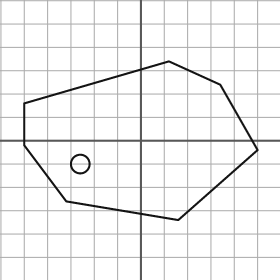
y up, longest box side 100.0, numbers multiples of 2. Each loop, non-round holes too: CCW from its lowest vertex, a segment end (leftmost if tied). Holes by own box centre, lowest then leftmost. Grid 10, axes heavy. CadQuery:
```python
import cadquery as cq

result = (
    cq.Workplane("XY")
    .moveTo(16.0, -34.0)
    .lineTo(50.0, -4.0)
    .lineTo(34.0, 24.0)
    .lineTo(12.0, 34.0)
    .lineTo(-50.0, 16.0)
    .lineTo(-50.0, -2.0)
    .lineTo(-32.0, -26.0)
    .close()
    .moveTo(-26.0, -10.0)
    .circle(4.0)
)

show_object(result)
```